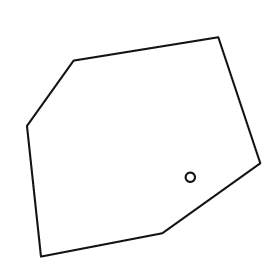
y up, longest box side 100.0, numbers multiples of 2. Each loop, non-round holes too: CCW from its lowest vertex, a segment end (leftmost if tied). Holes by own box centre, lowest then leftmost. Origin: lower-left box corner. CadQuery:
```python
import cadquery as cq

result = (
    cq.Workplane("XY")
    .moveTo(6.0, 0.0)
    .lineTo(58.0, 10.0)
    .lineTo(100.0, 40.0)
    .lineTo(82.0, 94.0)
    .lineTo(20.0, 84.0)
    .lineTo(0.0, 56.0)
    .close()
    .moveTo(70.0, 34.0)
    .circle(2.0)
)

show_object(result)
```